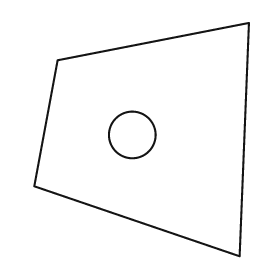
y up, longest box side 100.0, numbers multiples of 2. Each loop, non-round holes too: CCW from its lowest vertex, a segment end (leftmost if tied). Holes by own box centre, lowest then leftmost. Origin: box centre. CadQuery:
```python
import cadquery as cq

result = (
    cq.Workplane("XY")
    .moveTo(42.0, -50.0)
    .lineTo(46.0, 50.0)
    .lineTo(-36.0, 34.0)
    .lineTo(-46.0, -20.0)
    .close()
    .moveTo(-4.0, 2.0)
    .circle(10.0)
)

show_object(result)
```